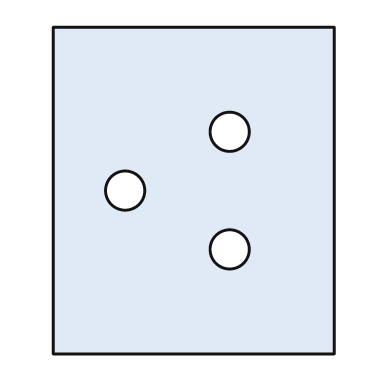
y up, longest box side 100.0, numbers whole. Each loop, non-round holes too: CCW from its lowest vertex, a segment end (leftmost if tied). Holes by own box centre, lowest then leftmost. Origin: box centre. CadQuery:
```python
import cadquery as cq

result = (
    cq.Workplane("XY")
    .moveTo(-43.0, -50.0)
    .lineTo(43.0, -50.0)
    .lineTo(43.0, 50.0)
    .lineTo(-43.0, 50.0)
    .close()
    .moveTo(11.0, -18.0)
    .circle(6.0)
    .moveTo(-21.0, 0.0)
    .circle(6.0)
    .moveTo(11.0, 18.0)
    .circle(6.0)
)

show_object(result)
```